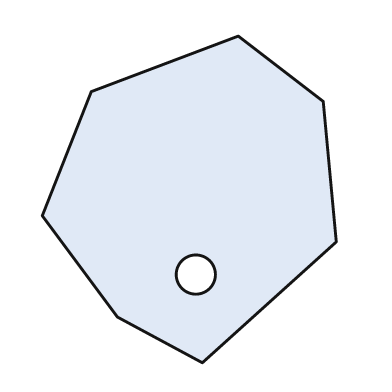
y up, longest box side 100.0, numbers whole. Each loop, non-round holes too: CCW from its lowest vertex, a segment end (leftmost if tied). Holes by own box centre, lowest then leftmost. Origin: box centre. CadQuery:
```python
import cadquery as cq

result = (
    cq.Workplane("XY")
    .moveTo(4.0, -50.0)
    .lineTo(45.0, -13.0)
    .lineTo(41.0, 30.0)
    .lineTo(15.0, 50.0)
    .lineTo(-30.0, 33.0)
    .lineTo(-45.0, -5.0)
    .lineTo(-22.0, -36.0)
    .close()
    .moveTo(2.0, -23.0)
    .circle(6.0)
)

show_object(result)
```